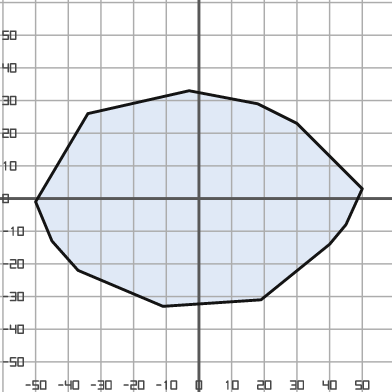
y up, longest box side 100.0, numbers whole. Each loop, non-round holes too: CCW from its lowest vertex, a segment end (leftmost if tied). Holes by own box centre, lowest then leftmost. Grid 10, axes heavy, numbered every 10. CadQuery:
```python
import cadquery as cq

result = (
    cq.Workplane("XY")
    .moveTo(-11.0, -33.0)
    .lineTo(19.0, -31.0)
    .lineTo(40.0, -14.0)
    .lineTo(45.0, -8.0)
    .lineTo(50.0, 3.0)
    .lineTo(30.0, 23.0)
    .lineTo(18.0, 29.0)
    .lineTo(-3.0, 33.0)
    .lineTo(-34.0, 26.0)
    .lineTo(-50.0, -1.0)
    .lineTo(-45.0, -13.0)
    .lineTo(-37.0, -22.0)
    .close()
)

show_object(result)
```